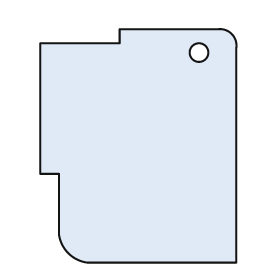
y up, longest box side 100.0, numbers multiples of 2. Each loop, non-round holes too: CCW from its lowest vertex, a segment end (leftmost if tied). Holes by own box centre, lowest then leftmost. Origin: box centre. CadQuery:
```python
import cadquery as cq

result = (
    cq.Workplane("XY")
    .moveTo(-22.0, -50.0)
    .lineTo(42.0, -50.0)
    .lineTo(42.0, 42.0)
    .threePointArc((40.0, 48.0), (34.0, 50.0))
    .lineTo(-8.0, 50.0)
    .lineTo(-8.0, 44.0)
    .lineTo(-42.0, 44.0)
    .lineTo(-42.0, -12.0)
    .lineTo(-34.0, -12.0)
    .lineTo(-34.0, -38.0)
    .threePointArc((-30.0, -46.0), (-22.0, -50.0))
    .close()
    .moveTo(26.0, 40.0)
    .circle(4.0)
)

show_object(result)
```